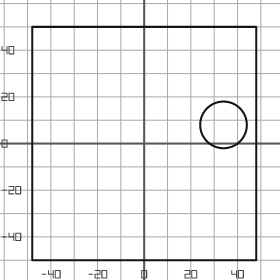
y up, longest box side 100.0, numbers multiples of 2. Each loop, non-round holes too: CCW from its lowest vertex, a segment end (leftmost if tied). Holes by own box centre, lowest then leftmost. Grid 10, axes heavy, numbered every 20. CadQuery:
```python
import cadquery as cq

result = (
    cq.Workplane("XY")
    .moveTo(-48.0, -50.0)
    .lineTo(48.0, -50.0)
    .lineTo(48.0, 50.0)
    .lineTo(-48.0, 50.0)
    .close()
    .moveTo(34.0, 8.0)
    .circle(10.0)
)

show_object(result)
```